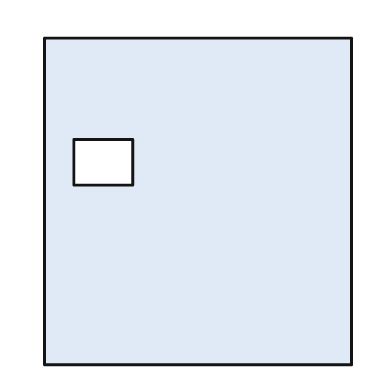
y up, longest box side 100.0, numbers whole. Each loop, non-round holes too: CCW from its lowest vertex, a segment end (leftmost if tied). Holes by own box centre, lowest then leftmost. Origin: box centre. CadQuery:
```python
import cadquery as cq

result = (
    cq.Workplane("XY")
    .moveTo(-47.0, -50.0)
    .lineTo(47.0, -50.0)
    .lineTo(47.0, 50.0)
    .lineTo(-47.0, 50.0)
    .close()
    .moveTo(-38.0, 5.0)
    .lineTo(-20.0, 5.0)
    .lineTo(-20.0, 19.0)
    .lineTo(-38.0, 19.0)
    .close()
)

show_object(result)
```